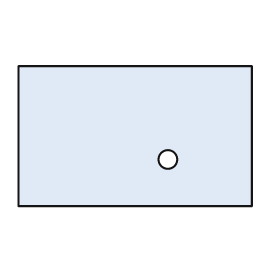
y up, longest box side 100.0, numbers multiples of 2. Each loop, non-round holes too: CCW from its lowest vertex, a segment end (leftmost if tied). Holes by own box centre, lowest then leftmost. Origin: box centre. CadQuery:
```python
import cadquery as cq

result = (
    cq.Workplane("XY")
    .moveTo(-50.0, -30.0)
    .lineTo(50.0, -30.0)
    .lineTo(50.0, 30.0)
    .lineTo(-50.0, 30.0)
    .close()
    .moveTo(14.0, -10.0)
    .circle(4.0)
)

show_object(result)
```